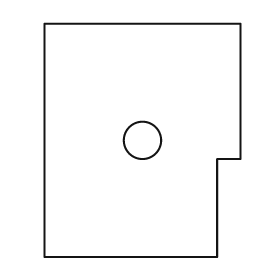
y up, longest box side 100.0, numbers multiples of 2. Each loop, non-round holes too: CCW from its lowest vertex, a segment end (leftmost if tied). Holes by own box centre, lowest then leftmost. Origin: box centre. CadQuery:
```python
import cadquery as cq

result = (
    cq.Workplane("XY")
    .moveTo(-42.0, -50.0)
    .lineTo(32.0, -50.0)
    .lineTo(32.0, -8.0)
    .lineTo(42.0, -8.0)
    .lineTo(42.0, 50.0)
    .lineTo(-42.0, 50.0)
    .close()
    .moveTo(0.0, 0.0)
    .circle(8.0)
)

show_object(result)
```